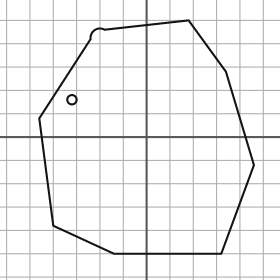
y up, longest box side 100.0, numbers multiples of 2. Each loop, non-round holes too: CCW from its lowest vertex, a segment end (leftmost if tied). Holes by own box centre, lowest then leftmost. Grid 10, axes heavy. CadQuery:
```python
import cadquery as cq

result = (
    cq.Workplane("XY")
    .moveTo(-14.0, -50.0)
    .lineTo(32.0, -50.0)
    .lineTo(46.0, -12.0)
    .lineTo(34.0, 28.0)
    .lineTo(18.0, 50.0)
    .lineTo(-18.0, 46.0)
    .threePointArc((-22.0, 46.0), (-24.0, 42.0))
    .lineTo(-46.0, 8.0)
    .lineTo(-40.0, -38.0)
    .close()
    .moveTo(-32.0, 16.0)
    .circle(2.0)
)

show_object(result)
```